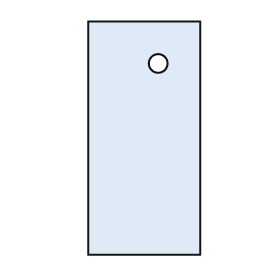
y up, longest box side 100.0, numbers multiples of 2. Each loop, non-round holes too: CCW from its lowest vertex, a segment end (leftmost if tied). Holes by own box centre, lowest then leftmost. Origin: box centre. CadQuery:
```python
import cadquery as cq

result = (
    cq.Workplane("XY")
    .moveTo(-24.0, -50.0)
    .lineTo(24.0, -50.0)
    .lineTo(24.0, 50.0)
    .lineTo(-24.0, 50.0)
    .close()
    .moveTo(6.0, 32.0)
    .circle(4.0)
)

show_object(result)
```